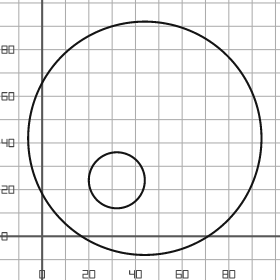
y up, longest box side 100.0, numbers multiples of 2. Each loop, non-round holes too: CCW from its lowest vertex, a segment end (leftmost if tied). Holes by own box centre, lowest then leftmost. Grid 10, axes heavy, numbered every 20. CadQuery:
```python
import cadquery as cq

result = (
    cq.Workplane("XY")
    .moveTo(44.0, 42.0)
    .circle(50.0)
    .moveTo(32.0, 24.0)
    .circle(12.0)
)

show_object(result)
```